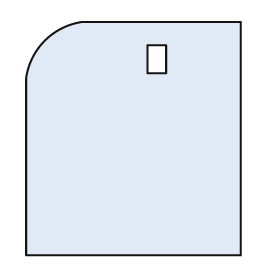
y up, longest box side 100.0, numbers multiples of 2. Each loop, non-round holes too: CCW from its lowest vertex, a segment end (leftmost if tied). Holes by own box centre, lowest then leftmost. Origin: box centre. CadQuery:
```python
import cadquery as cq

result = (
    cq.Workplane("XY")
    .moveTo(-46.0, -50.0)
    .lineTo(46.0, -50.0)
    .lineTo(46.0, 50.0)
    .lineTo(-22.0, 50.0)
    .threePointArc((-38.0, 42.0), (-46.0, 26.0))
    .close()
    .moveTo(6.0, 28.0)
    .lineTo(14.0, 28.0)
    .lineTo(14.0, 40.0)
    .lineTo(6.0, 40.0)
    .close()
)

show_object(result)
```